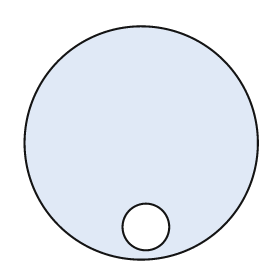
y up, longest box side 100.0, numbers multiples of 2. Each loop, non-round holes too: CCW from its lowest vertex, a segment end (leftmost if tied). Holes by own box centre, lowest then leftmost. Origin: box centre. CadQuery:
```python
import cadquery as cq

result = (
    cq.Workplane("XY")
    .moveTo(0.0, 0.0)
    .circle(50.0)
    .moveTo(2.0, -36.0)
    .circle(10.0)
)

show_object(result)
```